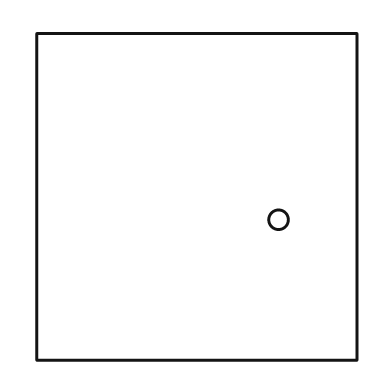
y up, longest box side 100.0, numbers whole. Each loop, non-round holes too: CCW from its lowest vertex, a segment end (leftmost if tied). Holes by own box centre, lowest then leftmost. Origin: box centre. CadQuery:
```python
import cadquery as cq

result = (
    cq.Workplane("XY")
    .moveTo(-49.0, -50.0)
    .lineTo(49.0, -50.0)
    .lineTo(49.0, 50.0)
    .lineTo(-49.0, 50.0)
    .close()
    .moveTo(25.0, -7.0)
    .circle(3.0)
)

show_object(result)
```